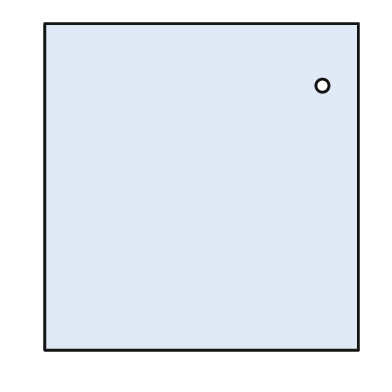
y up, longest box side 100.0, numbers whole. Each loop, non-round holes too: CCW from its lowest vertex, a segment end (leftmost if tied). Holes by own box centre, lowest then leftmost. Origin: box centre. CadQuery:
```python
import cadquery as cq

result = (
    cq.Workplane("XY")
    .moveTo(-48.0, -50.0)
    .lineTo(48.0, -50.0)
    .lineTo(48.0, 50.0)
    .lineTo(-48.0, 50.0)
    .close()
    .moveTo(37.0, 31.0)
    .circle(2.0)
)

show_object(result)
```